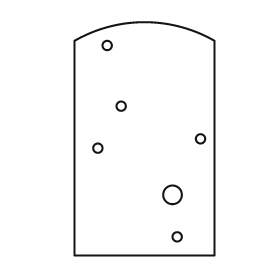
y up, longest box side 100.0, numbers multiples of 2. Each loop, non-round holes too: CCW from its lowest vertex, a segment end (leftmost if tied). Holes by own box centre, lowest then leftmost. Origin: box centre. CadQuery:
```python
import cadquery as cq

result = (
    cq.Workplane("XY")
    .moveTo(-30.0, -50.0)
    .lineTo(30.0, -50.0)
    .lineTo(30.0, 42.0)
    .threePointArc((0.0, 50.0), (-30.0, 42.0))
    .close()
    .moveTo(14.0, -42.0)
    .circle(2.0)
    .moveTo(12.0, -24.0)
    .circle(4.0)
    .moveTo(-20.0, -4.0)
    .circle(2.0)
    .moveTo(24.0, 0.0)
    .circle(2.0)
    .moveTo(-10.0, 14.0)
    .circle(2.0)
    .moveTo(-16.0, 40.0)
    .circle(2.0)
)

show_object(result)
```